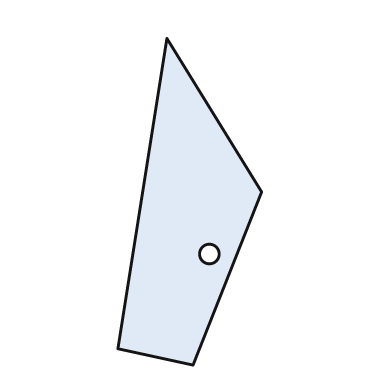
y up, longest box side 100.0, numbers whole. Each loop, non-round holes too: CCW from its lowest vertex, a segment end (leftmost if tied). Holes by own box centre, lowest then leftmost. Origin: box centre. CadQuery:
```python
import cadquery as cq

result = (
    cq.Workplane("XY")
    .moveTo(1.0, -50.0)
    .lineTo(22.0, 3.0)
    .lineTo(-7.0, 50.0)
    .lineTo(-22.0, -45.0)
    .close()
    .moveTo(6.0, -16.0)
    .circle(3.0)
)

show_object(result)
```